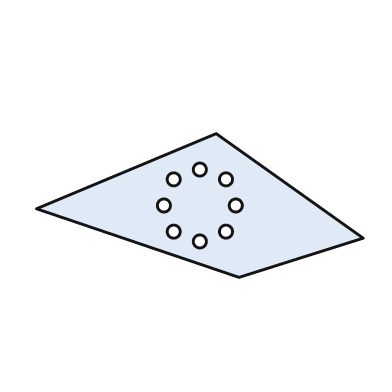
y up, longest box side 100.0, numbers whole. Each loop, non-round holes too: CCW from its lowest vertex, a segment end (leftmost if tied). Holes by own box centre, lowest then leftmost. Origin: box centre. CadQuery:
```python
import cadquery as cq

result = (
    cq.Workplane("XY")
    .moveTo(12.0, -22.0)
    .lineTo(50.0, -10.0)
    .lineTo(5.0, 22.0)
    .lineTo(-50.0, -1.0)
    .close()
    .moveTo(0.0, -11.0)
    .circle(2.0)
    .moveTo(-8.0, -8.0)
    .circle(2.0)
    .moveTo(8.0, -8.0)
    .circle(2.0)
    .moveTo(-11.0, 0.0)
    .circle(2.0)
    .moveTo(11.0, 0.0)
    .circle(2.0)
    .moveTo(-8.0, 8.0)
    .circle(2.0)
    .moveTo(8.0, 8.0)
    .circle(2.0)
    .moveTo(0.0, 11.0)
    .circle(2.0)
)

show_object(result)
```